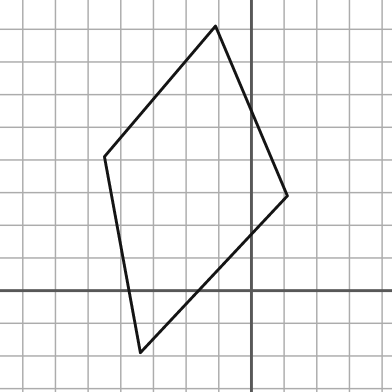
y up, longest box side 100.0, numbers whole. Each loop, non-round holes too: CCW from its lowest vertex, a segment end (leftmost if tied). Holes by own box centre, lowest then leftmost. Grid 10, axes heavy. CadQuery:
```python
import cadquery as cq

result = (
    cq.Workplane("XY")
    .moveTo(-34.0, -19.0)
    .lineTo(11.0, 29.0)
    .lineTo(-11.0, 81.0)
    .lineTo(-45.0, 41.0)
    .close()
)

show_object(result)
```